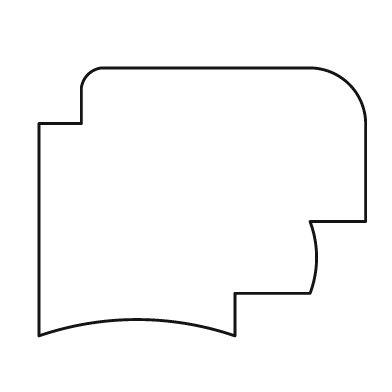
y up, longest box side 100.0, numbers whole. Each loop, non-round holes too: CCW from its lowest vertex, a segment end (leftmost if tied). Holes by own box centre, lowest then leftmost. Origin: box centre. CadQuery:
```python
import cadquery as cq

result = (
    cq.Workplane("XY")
    .moveTo(-50.0, -41.0)
    .threePointArc((-20.0, -36.0), (10.0, -41.0))
    .lineTo(10.0, -28.0)
    .lineTo(33.0, -28.0)
    .threePointArc((35.0, -17.0), (33.0, -6.0))
    .lineTo(50.0, -6.0)
    .lineTo(50.0, 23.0)
    .threePointArc((45.0, 36.0), (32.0, 41.0))
    .lineTo(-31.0, 41.0)
    .threePointArc((-35.0, 39.0), (-37.0, 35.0))
    .lineTo(-37.0, 24.0)
    .lineTo(-50.0, 24.0)
    .close()
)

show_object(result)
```